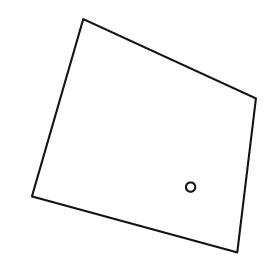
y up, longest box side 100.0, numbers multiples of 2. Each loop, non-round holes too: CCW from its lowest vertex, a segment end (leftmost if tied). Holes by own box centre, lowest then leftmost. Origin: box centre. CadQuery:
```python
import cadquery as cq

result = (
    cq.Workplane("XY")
    .moveTo(40.0, -50.0)
    .lineTo(48.0, 16.0)
    .lineTo(-26.0, 50.0)
    .lineTo(-48.0, -26.0)
    .close()
    .moveTo(20.0, -22.0)
    .circle(2.0)
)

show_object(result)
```